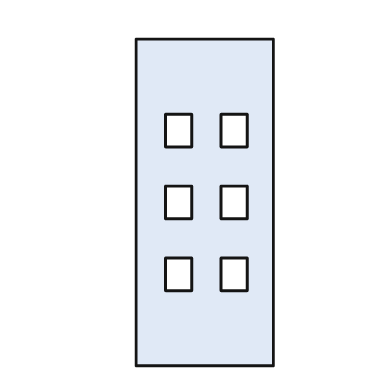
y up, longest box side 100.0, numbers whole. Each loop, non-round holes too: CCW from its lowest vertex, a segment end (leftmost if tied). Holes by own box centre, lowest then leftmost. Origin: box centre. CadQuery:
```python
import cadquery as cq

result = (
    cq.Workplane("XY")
    .moveTo(-21.0, -50.0)
    .lineTo(21.0, -50.0)
    .lineTo(21.0, 50.0)
    .lineTo(-21.0, 50.0)
    .close()
    .moveTo(-12.0, -27.0)
    .lineTo(-4.0, -27.0)
    .lineTo(-4.0, -17.0)
    .lineTo(-12.0, -17.0)
    .close()
    .moveTo(5.0, -27.0)
    .lineTo(13.0, -27.0)
    .lineTo(13.0, -17.0)
    .lineTo(5.0, -17.0)
    .close()
    .moveTo(-12.0, -5.0)
    .lineTo(-4.0, -5.0)
    .lineTo(-4.0, 5.0)
    .lineTo(-12.0, 5.0)
    .close()
    .moveTo(5.0, -5.0)
    .lineTo(13.0, -5.0)
    .lineTo(13.0, 5.0)
    .lineTo(5.0, 5.0)
    .close()
    .moveTo(-12.0, 17.0)
    .lineTo(-4.0, 17.0)
    .lineTo(-4.0, 27.0)
    .lineTo(-12.0, 27.0)
    .close()
    .moveTo(5.0, 17.0)
    .lineTo(13.0, 17.0)
    .lineTo(13.0, 27.0)
    .lineTo(5.0, 27.0)
    .close()
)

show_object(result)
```